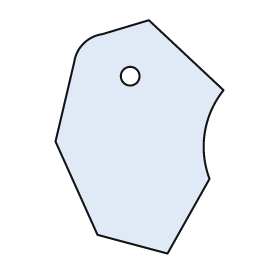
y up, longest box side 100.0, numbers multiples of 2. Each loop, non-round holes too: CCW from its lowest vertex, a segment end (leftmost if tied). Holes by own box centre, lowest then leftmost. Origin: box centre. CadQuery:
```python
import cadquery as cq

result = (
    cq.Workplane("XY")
    .moveTo(12.0, -50.0)
    .lineTo(30.0, -18.0)
    .threePointArc((28.0, 2.0), (36.0, 20.0))
    .lineTo(4.0, 50.0)
    .lineTo(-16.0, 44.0)
    .threePointArc((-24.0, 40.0), (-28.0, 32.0))
    .lineTo(-36.0, -2.0)
    .lineTo(-18.0, -42.0)
    .close()
    .moveTo(-4.0, 26.0)
    .circle(4.0)
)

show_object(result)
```